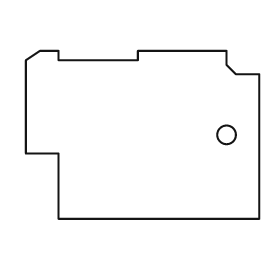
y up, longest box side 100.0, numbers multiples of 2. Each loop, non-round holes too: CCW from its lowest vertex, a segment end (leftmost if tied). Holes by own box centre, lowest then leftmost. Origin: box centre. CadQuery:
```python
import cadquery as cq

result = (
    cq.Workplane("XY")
    .moveTo(-36.0, -36.0)
    .lineTo(50.0, -36.0)
    .lineTo(50.0, 26.0)
    .lineTo(40.0, 26.0)
    .lineTo(36.0, 30.0)
    .lineTo(36.0, 36.0)
    .lineTo(-2.0, 36.0)
    .lineTo(-2.0, 32.0)
    .lineTo(-36.0, 32.0)
    .lineTo(-36.0, 36.0)
    .lineTo(-44.0, 36.0)
    .lineTo(-50.0, 32.0)
    .lineTo(-50.0, -8.0)
    .lineTo(-36.0, -8.0)
    .close()
    .moveTo(36.0, 0.0)
    .circle(4.0)
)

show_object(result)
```